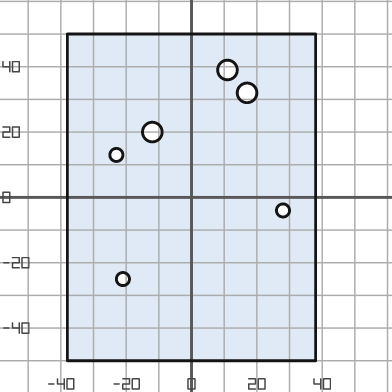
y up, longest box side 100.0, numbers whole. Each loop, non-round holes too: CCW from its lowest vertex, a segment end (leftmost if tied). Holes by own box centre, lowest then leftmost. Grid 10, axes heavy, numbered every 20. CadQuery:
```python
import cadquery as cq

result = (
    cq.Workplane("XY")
    .moveTo(-38.0, -50.0)
    .lineTo(38.0, -50.0)
    .lineTo(38.0, 50.0)
    .lineTo(-38.0, 50.0)
    .close()
    .moveTo(-21.0, -25.0)
    .circle(2.0)
    .moveTo(28.0, -4.0)
    .circle(2.0)
    .moveTo(-23.0, 13.0)
    .circle(2.0)
    .moveTo(-12.0, 20.0)
    .circle(3.0)
    .moveTo(17.0, 32.0)
    .circle(3.0)
    .moveTo(11.0, 39.0)
    .circle(3.0)
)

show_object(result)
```